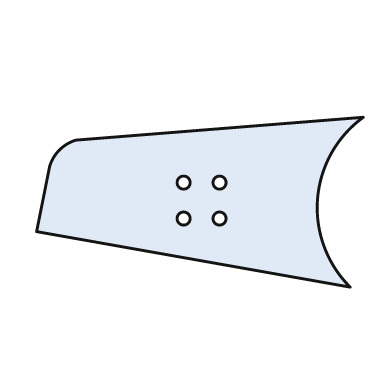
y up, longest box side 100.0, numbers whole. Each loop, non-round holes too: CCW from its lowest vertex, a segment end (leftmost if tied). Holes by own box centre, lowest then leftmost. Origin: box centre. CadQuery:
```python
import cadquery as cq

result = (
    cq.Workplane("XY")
    .moveTo(46.0, -26.0)
    .threePointArc((36.0, 1.0), (50.0, 26.0))
    .lineTo(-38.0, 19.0)
    .threePointArc((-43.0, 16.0), (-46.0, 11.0))
    .lineTo(-50.0, -9.0)
    .close()
    .moveTo(-5.0, -5.0)
    .circle(2.0)
    .moveTo(6.0, -5.0)
    .circle(2.0)
    .moveTo(-5.0, 6.0)
    .circle(2.0)
    .moveTo(6.0, 6.0)
    .circle(2.0)
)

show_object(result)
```